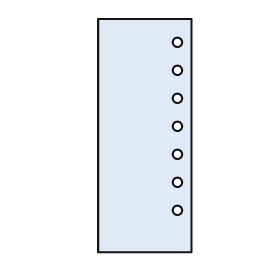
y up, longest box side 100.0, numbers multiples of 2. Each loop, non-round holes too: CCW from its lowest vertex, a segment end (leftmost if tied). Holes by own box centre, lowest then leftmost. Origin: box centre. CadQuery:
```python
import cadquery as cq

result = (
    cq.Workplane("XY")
    .moveTo(-20.0, -50.0)
    .lineTo(20.0, -50.0)
    .lineTo(20.0, 50.0)
    .lineTo(-20.0, 50.0)
    .close()
    .moveTo(14.0, -32.0)
    .circle(2.0)
    .moveTo(14.0, -20.0)
    .circle(2.0)
    .moveTo(14.0, -8.0)
    .circle(2.0)
    .moveTo(14.0, 4.0)
    .circle(2.0)
    .moveTo(14.0, 16.0)
    .circle(2.0)
    .moveTo(14.0, 28.0)
    .circle(2.0)
    .moveTo(14.0, 40.0)
    .circle(2.0)
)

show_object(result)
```